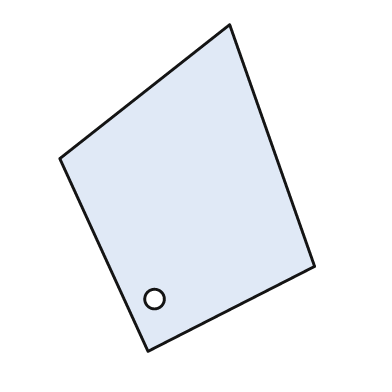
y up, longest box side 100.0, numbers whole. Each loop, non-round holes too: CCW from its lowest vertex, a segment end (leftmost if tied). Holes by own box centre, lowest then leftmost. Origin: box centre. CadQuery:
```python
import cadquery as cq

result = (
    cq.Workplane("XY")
    .moveTo(-12.0, -50.0)
    .lineTo(39.0, -24.0)
    .lineTo(13.0, 50.0)
    .lineTo(-39.0, 9.0)
    .close()
    .moveTo(-10.0, -34.0)
    .circle(3.0)
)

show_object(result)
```